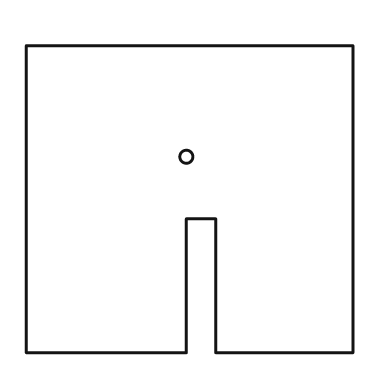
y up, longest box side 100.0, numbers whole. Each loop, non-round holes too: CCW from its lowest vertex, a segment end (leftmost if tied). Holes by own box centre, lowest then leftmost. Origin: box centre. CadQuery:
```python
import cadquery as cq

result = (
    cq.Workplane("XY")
    .moveTo(-50.0, -47.0)
    .lineTo(-1.0, -47.0)
    .lineTo(-1.0, -6.0)
    .lineTo(8.0, -6.0)
    .lineTo(8.0, -47.0)
    .lineTo(50.0, -47.0)
    .lineTo(50.0, 47.0)
    .lineTo(-50.0, 47.0)
    .close()
    .moveTo(-1.0, 13.0)
    .circle(2.0)
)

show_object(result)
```